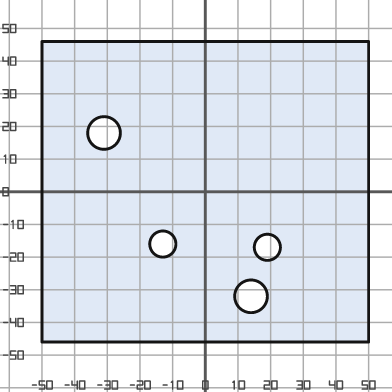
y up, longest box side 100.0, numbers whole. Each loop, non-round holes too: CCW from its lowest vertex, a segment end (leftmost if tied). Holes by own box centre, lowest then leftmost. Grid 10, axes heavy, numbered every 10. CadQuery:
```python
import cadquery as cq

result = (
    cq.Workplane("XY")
    .moveTo(-50.0, -46.0)
    .lineTo(50.0, -46.0)
    .lineTo(50.0, 46.0)
    .lineTo(-50.0, 46.0)
    .close()
    .moveTo(14.0, -32.0)
    .circle(5.0)
    .moveTo(19.0, -17.0)
    .circle(4.0)
    .moveTo(-13.0, -16.0)
    .circle(4.0)
    .moveTo(-31.0, 18.0)
    .circle(5.0)
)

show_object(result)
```